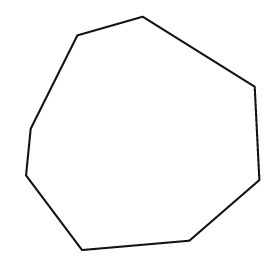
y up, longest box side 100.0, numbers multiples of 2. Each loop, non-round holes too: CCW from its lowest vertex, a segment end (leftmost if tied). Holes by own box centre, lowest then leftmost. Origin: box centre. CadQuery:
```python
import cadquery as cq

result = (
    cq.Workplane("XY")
    .moveTo(-26.0, -50.0)
    .lineTo(20.0, -46.0)
    .lineTo(50.0, -20.0)
    .lineTo(48.0, 20.0)
    .lineTo(0.0, 50.0)
    .lineTo(-28.0, 42.0)
    .lineTo(-48.0, 2.0)
    .lineTo(-50.0, -18.0)
    .close()
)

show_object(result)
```